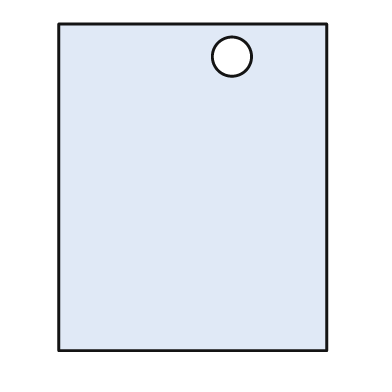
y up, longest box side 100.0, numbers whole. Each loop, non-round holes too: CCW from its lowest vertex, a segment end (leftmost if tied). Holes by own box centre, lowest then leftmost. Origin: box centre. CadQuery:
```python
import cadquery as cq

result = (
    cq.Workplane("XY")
    .moveTo(-41.0, -50.0)
    .lineTo(41.0, -50.0)
    .lineTo(41.0, 50.0)
    .lineTo(-41.0, 50.0)
    .close()
    .moveTo(12.0, 40.0)
    .circle(6.0)
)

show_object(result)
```